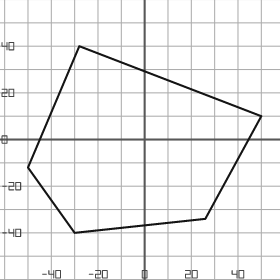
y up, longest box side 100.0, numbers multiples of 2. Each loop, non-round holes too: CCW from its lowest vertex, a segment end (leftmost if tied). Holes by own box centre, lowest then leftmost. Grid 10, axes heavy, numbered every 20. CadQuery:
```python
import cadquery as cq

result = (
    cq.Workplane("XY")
    .moveTo(-30.0, -40.0)
    .lineTo(26.0, -34.0)
    .lineTo(50.0, 10.0)
    .lineTo(-28.0, 40.0)
    .lineTo(-50.0, -12.0)
    .close()
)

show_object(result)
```